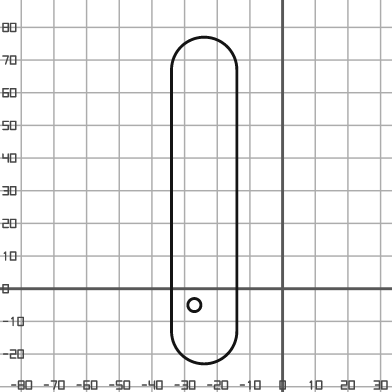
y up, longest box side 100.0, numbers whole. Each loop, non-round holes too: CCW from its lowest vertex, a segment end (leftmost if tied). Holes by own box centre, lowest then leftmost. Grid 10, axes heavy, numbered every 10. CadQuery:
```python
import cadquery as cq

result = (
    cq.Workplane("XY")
    .moveTo(-34.0, -13.0)
    .threePointArc((-24.0, -23.0), (-14.0, -13.0))
    .lineTo(-14.0, 67.0)
    .threePointArc((-24.0, 77.0), (-34.0, 67.0))
    .close()
    .moveTo(-27.0, -5.0)
    .circle(2.0)
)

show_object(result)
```